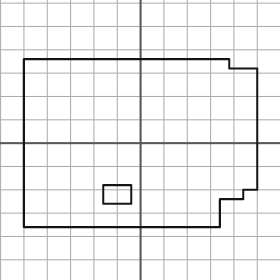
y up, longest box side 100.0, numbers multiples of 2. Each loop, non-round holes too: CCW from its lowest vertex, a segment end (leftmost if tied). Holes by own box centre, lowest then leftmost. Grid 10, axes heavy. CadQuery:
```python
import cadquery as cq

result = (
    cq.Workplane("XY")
    .moveTo(-50.0, -36.0)
    .lineTo(34.0, -36.0)
    .lineTo(34.0, -24.0)
    .lineTo(44.0, -24.0)
    .lineTo(44.0, -20.0)
    .lineTo(50.0, -20.0)
    .lineTo(50.0, 32.0)
    .lineTo(38.0, 32.0)
    .lineTo(38.0, 36.0)
    .lineTo(-50.0, 36.0)
    .close()
    .moveTo(-16.0, -26.0)
    .lineTo(-4.0, -26.0)
    .lineTo(-4.0, -18.0)
    .lineTo(-16.0, -18.0)
    .close()
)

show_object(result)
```